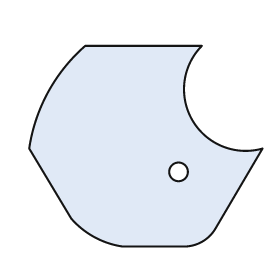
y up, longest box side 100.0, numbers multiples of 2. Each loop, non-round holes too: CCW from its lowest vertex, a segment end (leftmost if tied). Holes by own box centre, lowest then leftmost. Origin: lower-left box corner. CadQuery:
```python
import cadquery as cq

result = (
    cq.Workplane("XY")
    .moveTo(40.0, 0.0)
    .lineTo(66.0, 0.0)
    .threePointArc((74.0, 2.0), (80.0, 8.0))
    .lineTo(100.0, 42.0)
    .threePointArc((70.0, 54.0), (74.0, 86.0))
    .lineTo(24.0, 86.0)
    .threePointArc((8.0, 66.0), (0.0, 42.0))
    .lineTo(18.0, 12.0)
    .threePointArc((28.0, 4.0), (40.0, 0.0))
    .close()
    .moveTo(64.0, 32.0)
    .circle(4.0)
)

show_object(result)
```